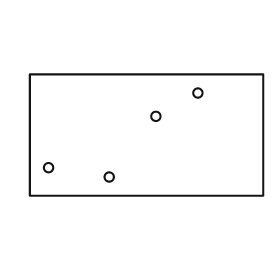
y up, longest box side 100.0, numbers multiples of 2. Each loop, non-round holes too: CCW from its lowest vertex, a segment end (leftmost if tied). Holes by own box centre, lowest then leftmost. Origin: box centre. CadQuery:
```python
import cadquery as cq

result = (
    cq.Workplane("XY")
    .moveTo(-50.0, -26.0)
    .lineTo(50.0, -26.0)
    .lineTo(50.0, 26.0)
    .lineTo(-50.0, 26.0)
    .close()
    .moveTo(-16.0, -18.0)
    .circle(2.0)
    .moveTo(-42.0, -14.0)
    .circle(2.0)
    .moveTo(4.0, 8.0)
    .circle(2.0)
    .moveTo(22.0, 18.0)
    .circle(2.0)
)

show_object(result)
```